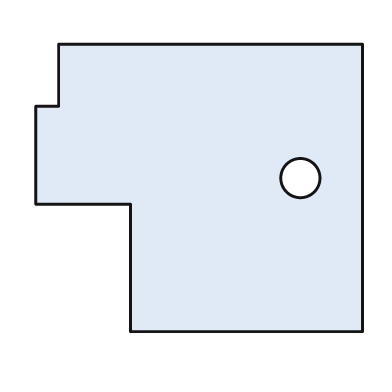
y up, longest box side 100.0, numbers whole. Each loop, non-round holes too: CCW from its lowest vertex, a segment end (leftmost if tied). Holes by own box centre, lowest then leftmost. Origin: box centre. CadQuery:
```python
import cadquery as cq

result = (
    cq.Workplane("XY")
    .moveTo(-21.0, -44.0)
    .lineTo(50.0, -44.0)
    .lineTo(50.0, 44.0)
    .lineTo(-43.0, 44.0)
    .lineTo(-43.0, 25.0)
    .lineTo(-50.0, 25.0)
    .lineTo(-50.0, -5.0)
    .lineTo(-21.0, -5.0)
    .close()
    .moveTo(31.0, 3.0)
    .circle(6.0)
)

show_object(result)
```